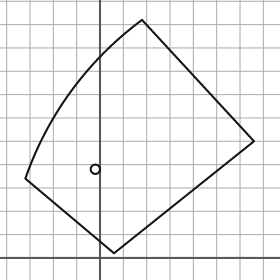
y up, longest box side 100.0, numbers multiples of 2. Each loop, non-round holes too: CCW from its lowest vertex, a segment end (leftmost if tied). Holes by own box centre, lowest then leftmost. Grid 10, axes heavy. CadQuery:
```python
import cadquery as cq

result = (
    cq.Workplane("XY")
    .moveTo(6.0, 2.0)
    .lineTo(66.0, 50.0)
    .lineTo(18.0, 102.0)
    .threePointArc((-12.0, 72.0), (-32.0, 34.0))
    .close()
    .moveTo(-2.0, 38.0)
    .circle(2.0)
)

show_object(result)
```